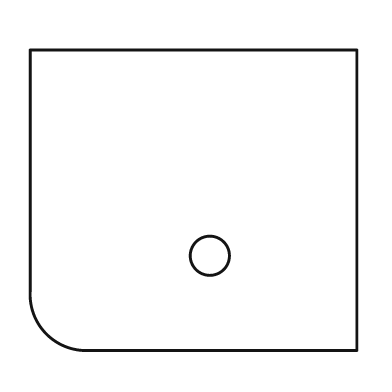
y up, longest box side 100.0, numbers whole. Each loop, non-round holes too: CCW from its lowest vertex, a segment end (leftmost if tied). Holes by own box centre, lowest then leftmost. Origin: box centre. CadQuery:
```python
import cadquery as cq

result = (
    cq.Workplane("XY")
    .moveTo(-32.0, -46.0)
    .lineTo(50.0, -46.0)
    .lineTo(50.0, 46.0)
    .lineTo(-50.0, 46.0)
    .lineTo(-50.0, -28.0)
    .threePointArc((-45.0, -41.0), (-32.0, -46.0))
    .close()
    .moveTo(5.0, -17.0)
    .circle(6.0)
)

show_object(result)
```